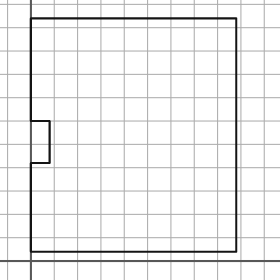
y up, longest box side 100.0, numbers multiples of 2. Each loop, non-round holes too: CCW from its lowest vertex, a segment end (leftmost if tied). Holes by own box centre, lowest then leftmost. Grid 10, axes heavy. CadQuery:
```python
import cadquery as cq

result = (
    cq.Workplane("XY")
    .moveTo(0.0, 4.0)
    .lineTo(88.0, 4.0)
    .lineTo(88.0, 104.0)
    .lineTo(0.0, 104.0)
    .lineTo(0.0, 60.0)
    .lineTo(8.0, 60.0)
    .lineTo(8.0, 42.0)
    .lineTo(0.0, 42.0)
    .close()
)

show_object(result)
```